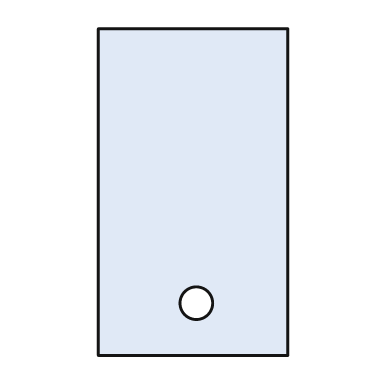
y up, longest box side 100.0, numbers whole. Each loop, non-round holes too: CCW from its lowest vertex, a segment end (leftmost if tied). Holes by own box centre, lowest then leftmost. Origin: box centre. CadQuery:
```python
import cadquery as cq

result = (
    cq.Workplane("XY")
    .moveTo(-29.0, -50.0)
    .lineTo(29.0, -50.0)
    .lineTo(29.0, 50.0)
    .lineTo(-29.0, 50.0)
    .close()
    .moveTo(1.0, -34.0)
    .circle(5.0)
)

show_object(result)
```